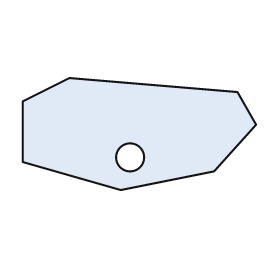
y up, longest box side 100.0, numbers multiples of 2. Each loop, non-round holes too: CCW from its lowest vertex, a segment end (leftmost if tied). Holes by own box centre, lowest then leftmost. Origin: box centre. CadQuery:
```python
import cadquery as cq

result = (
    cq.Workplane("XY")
    .moveTo(-8.0, -24.0)
    .lineTo(32.0, -16.0)
    .lineTo(50.0, 4.0)
    .lineTo(42.0, 18.0)
    .lineTo(-30.0, 24.0)
    .lineTo(-50.0, 14.0)
    .lineTo(-50.0, -12.0)
    .close()
    .moveTo(-4.0, -10.0)
    .circle(6.0)
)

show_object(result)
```